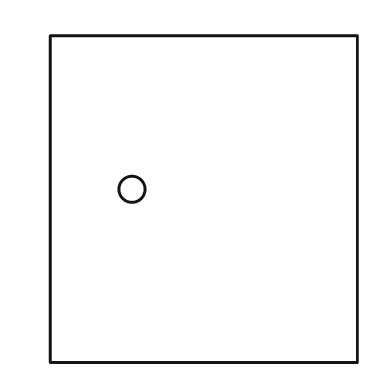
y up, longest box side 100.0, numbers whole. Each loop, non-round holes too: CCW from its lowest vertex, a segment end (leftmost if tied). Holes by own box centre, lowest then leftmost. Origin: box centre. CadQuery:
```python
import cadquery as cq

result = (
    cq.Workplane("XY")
    .moveTo(-47.0, -50.0)
    .lineTo(47.0, -50.0)
    .lineTo(47.0, 50.0)
    .lineTo(-47.0, 50.0)
    .close()
    .moveTo(-22.0, 3.0)
    .circle(4.0)
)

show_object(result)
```